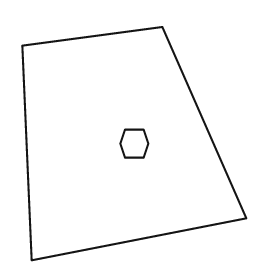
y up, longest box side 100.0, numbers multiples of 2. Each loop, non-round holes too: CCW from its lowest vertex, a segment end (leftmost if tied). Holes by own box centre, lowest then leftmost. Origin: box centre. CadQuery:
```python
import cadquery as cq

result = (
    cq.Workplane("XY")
    .moveTo(-44.0, -50.0)
    .lineTo(48.0, -32.0)
    .lineTo(12.0, 50.0)
    .lineTo(-48.0, 42.0)
    .close()
    .moveTo(-4.0, -6.0)
    .lineTo(4.0, -6.0)
    .lineTo(6.0, 0.0)
    .lineTo(4.0, 6.0)
    .lineTo(-4.0, 6.0)
    .lineTo(-6.0, 0.0)
    .close()
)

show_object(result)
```